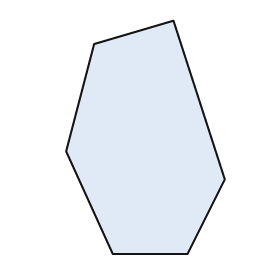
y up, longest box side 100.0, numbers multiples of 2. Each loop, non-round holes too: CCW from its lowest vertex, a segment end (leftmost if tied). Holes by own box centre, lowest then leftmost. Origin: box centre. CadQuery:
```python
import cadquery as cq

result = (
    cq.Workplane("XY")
    .moveTo(-14.0, -50.0)
    .lineTo(18.0, -50.0)
    .lineTo(34.0, -18.0)
    .lineTo(12.0, 50.0)
    .lineTo(-22.0, 40.0)
    .lineTo(-34.0, -6.0)
    .close()
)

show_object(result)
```